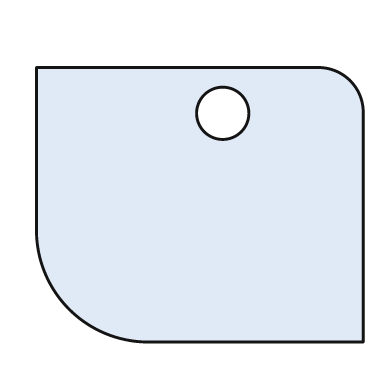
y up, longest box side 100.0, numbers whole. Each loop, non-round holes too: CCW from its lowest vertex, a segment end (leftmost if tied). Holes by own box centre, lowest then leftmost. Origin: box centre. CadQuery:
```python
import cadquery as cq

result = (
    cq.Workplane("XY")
    .moveTo(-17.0, -42.0)
    .lineTo(50.0, -42.0)
    .lineTo(50.0, 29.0)
    .threePointArc((46.0, 38.0), (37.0, 42.0))
    .lineTo(-50.0, 42.0)
    .lineTo(-50.0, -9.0)
    .threePointArc((-40.0, -32.0), (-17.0, -42.0))
    .close()
    .moveTo(7.0, 28.0)
    .circle(8.0)
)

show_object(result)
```